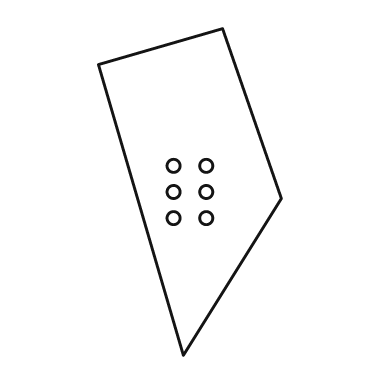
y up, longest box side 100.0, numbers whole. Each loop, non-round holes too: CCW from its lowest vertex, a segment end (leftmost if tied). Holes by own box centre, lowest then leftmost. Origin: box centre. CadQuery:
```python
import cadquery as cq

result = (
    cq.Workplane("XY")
    .moveTo(-2.0, -50.0)
    .lineTo(28.0, -2.0)
    .lineTo(10.0, 50.0)
    .lineTo(-28.0, 39.0)
    .close()
    .moveTo(-5.0, -8.0)
    .circle(2.0)
    .moveTo(5.0, -8.0)
    .circle(2.0)
    .moveTo(-5.0, 0.0)
    .circle(2.0)
    .moveTo(5.0, 0.0)
    .circle(2.0)
    .moveTo(-5.0, 8.0)
    .circle(2.0)
    .moveTo(5.0, 8.0)
    .circle(2.0)
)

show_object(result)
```